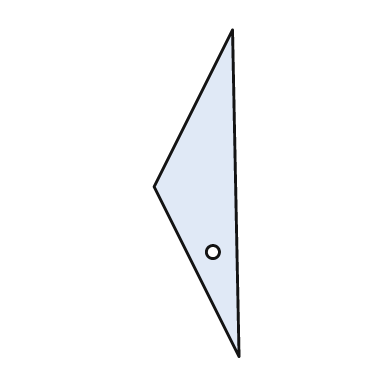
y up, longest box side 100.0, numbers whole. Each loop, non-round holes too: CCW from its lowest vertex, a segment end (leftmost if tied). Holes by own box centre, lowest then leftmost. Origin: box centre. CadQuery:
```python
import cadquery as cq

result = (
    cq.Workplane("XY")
    .moveTo(13.0, -50.0)
    .lineTo(11.0, 50.0)
    .lineTo(-13.0, 2.0)
    .close()
    .moveTo(5.0, -18.0)
    .circle(2.0)
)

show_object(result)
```